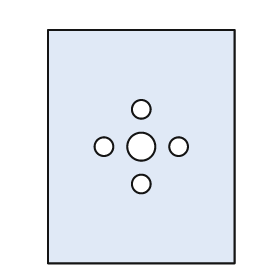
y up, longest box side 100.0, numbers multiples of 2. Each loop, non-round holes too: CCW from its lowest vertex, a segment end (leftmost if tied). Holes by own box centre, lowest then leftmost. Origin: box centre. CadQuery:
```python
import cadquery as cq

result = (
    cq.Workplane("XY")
    .moveTo(-40.0, -50.0)
    .lineTo(40.0, -50.0)
    .lineTo(40.0, 50.0)
    .lineTo(-40.0, 50.0)
    .close()
    .moveTo(0.0, -16.0)
    .circle(4.0)
    .moveTo(-16.0, 0.0)
    .circle(4.0)
    .moveTo(0.0, 0.0)
    .circle(6.0)
    .moveTo(16.0, 0.0)
    .circle(4.0)
    .moveTo(0.0, 16.0)
    .circle(4.0)
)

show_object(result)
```